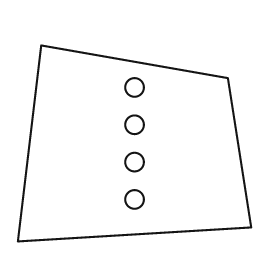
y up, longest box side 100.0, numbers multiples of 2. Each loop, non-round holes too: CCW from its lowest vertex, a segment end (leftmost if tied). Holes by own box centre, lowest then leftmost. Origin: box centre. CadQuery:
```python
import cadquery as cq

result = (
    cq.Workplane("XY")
    .moveTo(-50.0, -42.0)
    .lineTo(50.0, -36.0)
    .lineTo(40.0, 28.0)
    .lineTo(-40.0, 42.0)
    .close()
    .moveTo(0.0, -24.0)
    .circle(4.0)
    .moveTo(0.0, -8.0)
    .circle(4.0)
    .moveTo(0.0, 8.0)
    .circle(4.0)
    .moveTo(0.0, 24.0)
    .circle(4.0)
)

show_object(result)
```